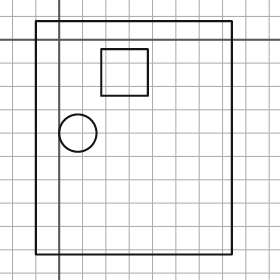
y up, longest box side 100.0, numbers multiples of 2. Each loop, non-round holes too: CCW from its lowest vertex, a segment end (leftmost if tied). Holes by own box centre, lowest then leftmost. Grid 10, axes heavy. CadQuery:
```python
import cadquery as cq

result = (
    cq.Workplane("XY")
    .moveTo(-10.0, -92.0)
    .lineTo(74.0, -92.0)
    .lineTo(74.0, 8.0)
    .lineTo(-10.0, 8.0)
    .close()
    .moveTo(8.0, -40.0)
    .circle(8.0)
    .moveTo(18.0, -24.0)
    .lineTo(38.0, -24.0)
    .lineTo(38.0, -4.0)
    .lineTo(18.0, -4.0)
    .close()
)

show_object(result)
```